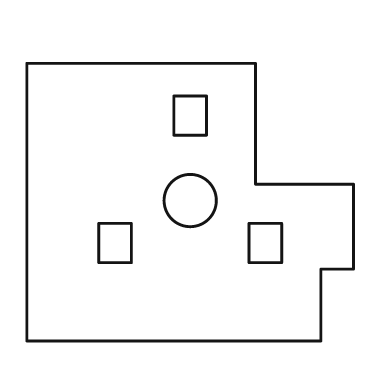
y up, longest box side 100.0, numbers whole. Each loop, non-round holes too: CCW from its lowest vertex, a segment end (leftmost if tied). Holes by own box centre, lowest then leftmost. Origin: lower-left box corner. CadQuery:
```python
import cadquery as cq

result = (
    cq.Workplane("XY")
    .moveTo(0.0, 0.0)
    .lineTo(90.0, 0.0)
    .lineTo(90.0, 22.0)
    .lineTo(100.0, 22.0)
    .lineTo(100.0, 48.0)
    .lineTo(70.0, 48.0)
    .lineTo(70.0, 85.0)
    .lineTo(0.0, 85.0)
    .close()
    .moveTo(22.0, 24.0)
    .lineTo(32.0, 24.0)
    .lineTo(32.0, 36.0)
    .lineTo(22.0, 36.0)
    .close()
    .moveTo(68.0, 24.0)
    .lineTo(78.0, 24.0)
    .lineTo(78.0, 36.0)
    .lineTo(68.0, 36.0)
    .close()
    .moveTo(50.0, 43.0)
    .circle(8.0)
    .moveTo(45.0, 63.0)
    .lineTo(55.0, 63.0)
    .lineTo(55.0, 75.0)
    .lineTo(45.0, 75.0)
    .close()
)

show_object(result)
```